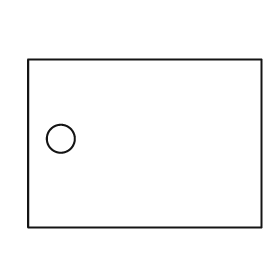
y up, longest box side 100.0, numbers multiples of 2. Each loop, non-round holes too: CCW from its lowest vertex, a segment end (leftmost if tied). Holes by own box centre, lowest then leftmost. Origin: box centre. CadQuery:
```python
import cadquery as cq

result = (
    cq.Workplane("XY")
    .moveTo(-50.0, -36.0)
    .lineTo(50.0, -36.0)
    .lineTo(50.0, 36.0)
    .lineTo(-50.0, 36.0)
    .close()
    .moveTo(-36.0, 2.0)
    .circle(6.0)
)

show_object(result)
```